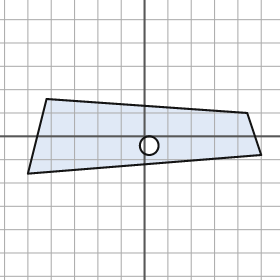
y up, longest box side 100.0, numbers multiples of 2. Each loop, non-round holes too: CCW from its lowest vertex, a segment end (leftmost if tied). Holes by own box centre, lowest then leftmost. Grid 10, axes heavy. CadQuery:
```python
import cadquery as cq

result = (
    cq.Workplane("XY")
    .moveTo(-50.0, -16.0)
    .lineTo(50.0, -8.0)
    .lineTo(44.0, 10.0)
    .lineTo(-42.0, 16.0)
    .close()
    .moveTo(2.0, -4.0)
    .circle(4.0)
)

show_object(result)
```